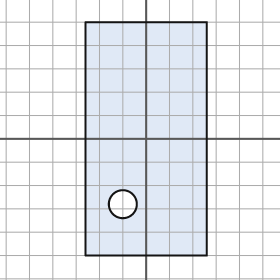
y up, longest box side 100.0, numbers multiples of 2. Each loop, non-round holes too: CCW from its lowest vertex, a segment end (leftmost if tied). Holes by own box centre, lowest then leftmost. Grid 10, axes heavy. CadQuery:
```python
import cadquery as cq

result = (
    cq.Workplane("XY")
    .moveTo(-26.0, -50.0)
    .lineTo(26.0, -50.0)
    .lineTo(26.0, 50.0)
    .lineTo(-26.0, 50.0)
    .close()
    .moveTo(-10.0, -28.0)
    .circle(6.0)
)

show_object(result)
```